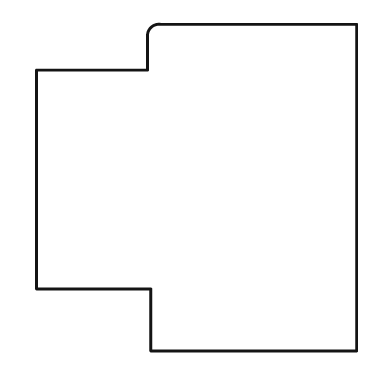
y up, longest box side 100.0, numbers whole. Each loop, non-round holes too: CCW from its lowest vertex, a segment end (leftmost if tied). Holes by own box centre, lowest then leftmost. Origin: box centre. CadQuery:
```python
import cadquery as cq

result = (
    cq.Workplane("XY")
    .moveTo(-14.0, -50.0)
    .lineTo(49.0, -50.0)
    .lineTo(49.0, 50.0)
    .lineTo(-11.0, 50.0)
    .threePointArc((-14.0, 49.0), (-15.0, 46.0))
    .lineTo(-15.0, 36.0)
    .lineTo(-49.0, 36.0)
    .lineTo(-49.0, -31.0)
    .lineTo(-14.0, -31.0)
    .close()
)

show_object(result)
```